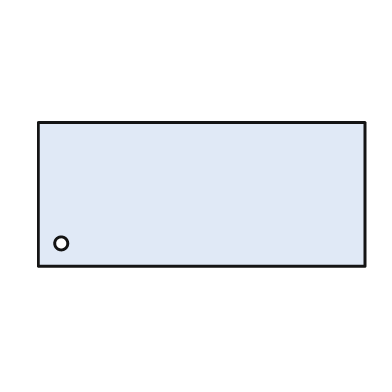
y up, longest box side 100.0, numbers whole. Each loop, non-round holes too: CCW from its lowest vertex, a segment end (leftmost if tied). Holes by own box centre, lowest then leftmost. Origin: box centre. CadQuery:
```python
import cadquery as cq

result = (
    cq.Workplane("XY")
    .moveTo(-50.0, -22.0)
    .lineTo(50.0, -22.0)
    .lineTo(50.0, 22.0)
    .lineTo(-50.0, 22.0)
    .close()
    .moveTo(-43.0, -15.0)
    .circle(2.0)
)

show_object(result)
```